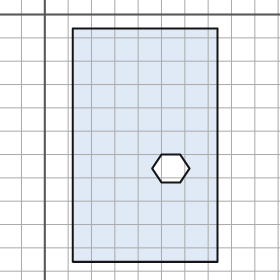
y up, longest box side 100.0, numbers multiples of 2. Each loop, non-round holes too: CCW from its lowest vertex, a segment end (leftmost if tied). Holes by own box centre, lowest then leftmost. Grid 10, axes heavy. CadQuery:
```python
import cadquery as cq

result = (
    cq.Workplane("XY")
    .moveTo(12.0, -106.0)
    .lineTo(74.0, -106.0)
    .lineTo(74.0, -6.0)
    .lineTo(12.0, -6.0)
    .close()
    .moveTo(50.0, -72.0)
    .lineTo(58.0, -72.0)
    .lineTo(62.0, -66.0)
    .lineTo(58.0, -60.0)
    .lineTo(50.0, -60.0)
    .lineTo(46.0, -66.0)
    .close()
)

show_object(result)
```